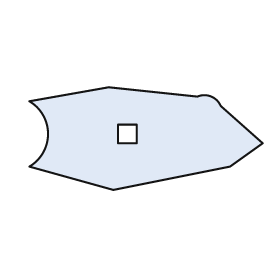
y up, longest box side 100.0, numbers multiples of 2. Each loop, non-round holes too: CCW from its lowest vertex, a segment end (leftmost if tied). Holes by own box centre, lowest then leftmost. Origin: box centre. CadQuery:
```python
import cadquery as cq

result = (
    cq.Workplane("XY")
    .moveTo(-14.0, -22.0)
    .lineTo(36.0, -12.0)
    .lineTo(50.0, -2.0)
    .lineTo(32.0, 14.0)
    .threePointArc((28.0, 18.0), (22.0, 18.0))
    .lineTo(-16.0, 22.0)
    .lineTo(-50.0, 16.0)
    .threePointArc((-42.0, 2.0), (-50.0, -12.0))
    .close()
    .moveTo(-12.0, -2.0)
    .lineTo(-4.0, -2.0)
    .lineTo(-4.0, 6.0)
    .lineTo(-12.0, 6.0)
    .close()
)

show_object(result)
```